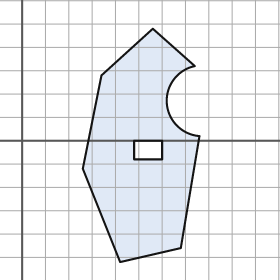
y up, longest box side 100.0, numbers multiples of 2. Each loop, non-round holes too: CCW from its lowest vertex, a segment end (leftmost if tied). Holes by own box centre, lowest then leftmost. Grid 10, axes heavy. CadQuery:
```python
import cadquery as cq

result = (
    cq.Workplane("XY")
    .moveTo(42.0, -52.0)
    .lineTo(68.0, -46.0)
    .lineTo(76.0, 2.0)
    .threePointArc((62.0, 16.0), (74.0, 32.0))
    .lineTo(56.0, 48.0)
    .lineTo(34.0, 28.0)
    .lineTo(26.0, -12.0)
    .close()
    .moveTo(48.0, -8.0)
    .lineTo(60.0, -8.0)
    .lineTo(60.0, 0.0)
    .lineTo(48.0, 0.0)
    .close()
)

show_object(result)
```